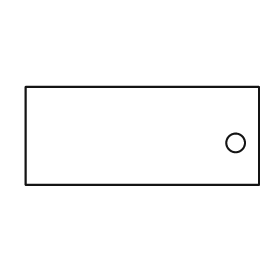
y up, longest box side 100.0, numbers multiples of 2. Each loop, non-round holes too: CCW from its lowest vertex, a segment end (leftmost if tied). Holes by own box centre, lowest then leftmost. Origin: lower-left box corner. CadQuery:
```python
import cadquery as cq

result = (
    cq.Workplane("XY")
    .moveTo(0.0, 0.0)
    .lineTo(100.0, 0.0)
    .lineTo(100.0, 42.0)
    .lineTo(0.0, 42.0)
    .close()
    .moveTo(90.0, 18.0)
    .circle(4.0)
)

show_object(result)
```